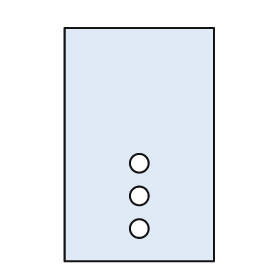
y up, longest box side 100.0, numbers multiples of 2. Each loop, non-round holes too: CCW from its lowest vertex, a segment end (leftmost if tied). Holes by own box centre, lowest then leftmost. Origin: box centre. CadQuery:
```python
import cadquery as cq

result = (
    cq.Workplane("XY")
    .moveTo(-32.0, -50.0)
    .lineTo(32.0, -50.0)
    .lineTo(32.0, 50.0)
    .lineTo(-32.0, 50.0)
    .close()
    .moveTo(0.0, -36.0)
    .circle(4.0)
    .moveTo(0.0, -22.0)
    .circle(4.0)
    .moveTo(0.0, -8.0)
    .circle(4.0)
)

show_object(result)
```